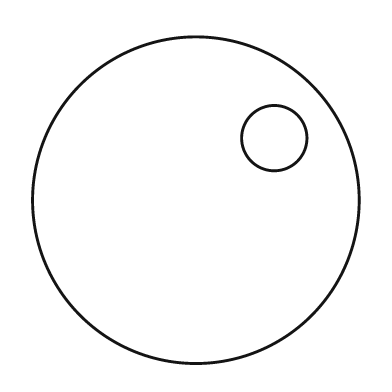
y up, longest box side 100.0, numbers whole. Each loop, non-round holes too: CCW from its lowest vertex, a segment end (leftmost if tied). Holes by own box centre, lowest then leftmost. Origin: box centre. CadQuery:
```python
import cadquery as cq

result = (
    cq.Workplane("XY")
    .moveTo(0.0, 0.0)
    .circle(50.0)
    .moveTo(24.0, 19.0)
    .circle(10.0)
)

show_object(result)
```